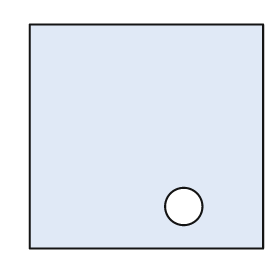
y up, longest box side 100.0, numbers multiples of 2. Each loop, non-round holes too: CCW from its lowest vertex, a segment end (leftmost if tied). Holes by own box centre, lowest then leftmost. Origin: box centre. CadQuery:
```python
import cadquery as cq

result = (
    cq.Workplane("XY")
    .moveTo(-50.0, -48.0)
    .lineTo(50.0, -48.0)
    .lineTo(50.0, 48.0)
    .lineTo(-50.0, 48.0)
    .close()
    .moveTo(16.0, -30.0)
    .circle(8.0)
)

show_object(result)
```